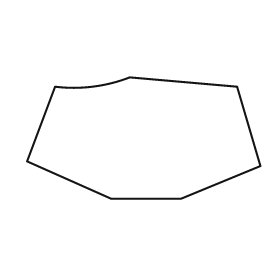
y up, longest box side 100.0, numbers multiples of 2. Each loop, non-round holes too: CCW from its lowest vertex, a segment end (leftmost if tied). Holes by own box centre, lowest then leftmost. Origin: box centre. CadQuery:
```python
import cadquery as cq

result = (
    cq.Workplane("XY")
    .moveTo(-14.0, -26.0)
    .lineTo(16.0, -26.0)
    .lineTo(50.0, -12.0)
    .lineTo(40.0, 22.0)
    .lineTo(-6.0, 26.0)
    .threePointArc((-22.0, 22.0), (-38.0, 22.0))
    .lineTo(-50.0, -10.0)
    .close()
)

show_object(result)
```